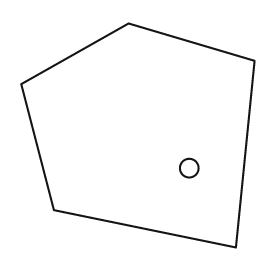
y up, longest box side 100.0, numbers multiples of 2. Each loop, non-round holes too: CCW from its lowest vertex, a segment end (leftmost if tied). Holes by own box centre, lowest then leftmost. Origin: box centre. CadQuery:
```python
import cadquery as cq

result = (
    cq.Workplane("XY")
    .moveTo(42.0, -48.0)
    .lineTo(50.0, 32.0)
    .lineTo(-4.0, 48.0)
    .lineTo(-50.0, 22.0)
    .lineTo(-36.0, -32.0)
    .close()
    .moveTo(22.0, -14.0)
    .circle(4.0)
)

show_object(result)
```